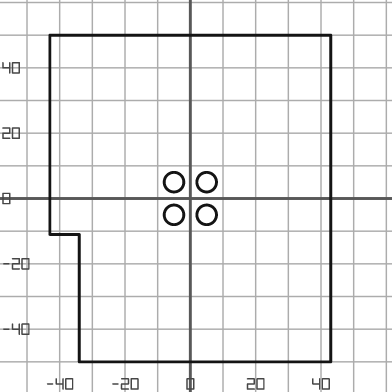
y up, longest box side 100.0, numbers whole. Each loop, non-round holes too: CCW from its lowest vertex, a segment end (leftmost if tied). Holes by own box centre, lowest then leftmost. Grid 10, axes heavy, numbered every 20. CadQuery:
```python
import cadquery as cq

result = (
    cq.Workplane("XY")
    .moveTo(-34.0, -50.0)
    .lineTo(43.0, -50.0)
    .lineTo(43.0, 50.0)
    .lineTo(-43.0, 50.0)
    .lineTo(-43.0, -11.0)
    .lineTo(-34.0, -11.0)
    .close()
    .moveTo(-5.0, -5.0)
    .circle(3.0)
    .moveTo(5.0, -5.0)
    .circle(3.0)
    .moveTo(-5.0, 5.0)
    .circle(3.0)
    .moveTo(5.0, 5.0)
    .circle(3.0)
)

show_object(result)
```